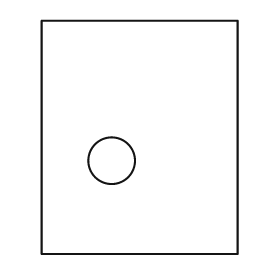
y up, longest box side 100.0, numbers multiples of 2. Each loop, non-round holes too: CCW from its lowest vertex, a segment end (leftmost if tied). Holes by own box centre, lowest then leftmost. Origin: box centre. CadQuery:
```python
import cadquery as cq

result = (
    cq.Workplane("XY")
    .moveTo(-42.0, -50.0)
    .lineTo(42.0, -50.0)
    .lineTo(42.0, 50.0)
    .lineTo(-42.0, 50.0)
    .close()
    .moveTo(-12.0, -10.0)
    .circle(10.0)
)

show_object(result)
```